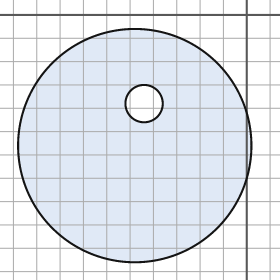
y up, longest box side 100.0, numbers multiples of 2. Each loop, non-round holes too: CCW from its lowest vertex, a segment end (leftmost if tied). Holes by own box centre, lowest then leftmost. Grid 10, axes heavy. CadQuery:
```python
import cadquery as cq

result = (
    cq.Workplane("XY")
    .moveTo(-48.0, -56.0)
    .circle(50.0)
    .moveTo(-44.0, -38.0)
    .circle(8.0)
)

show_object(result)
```